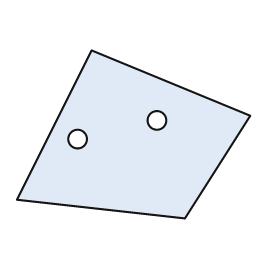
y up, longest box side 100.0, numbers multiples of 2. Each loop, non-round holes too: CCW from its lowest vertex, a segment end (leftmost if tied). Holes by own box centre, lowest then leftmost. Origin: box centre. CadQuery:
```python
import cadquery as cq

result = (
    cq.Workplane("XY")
    .moveTo(22.0, -36.0)
    .lineTo(50.0, 8.0)
    .lineTo(-18.0, 36.0)
    .lineTo(-50.0, -28.0)
    .close()
    .moveTo(-24.0, -2.0)
    .circle(4.0)
    .moveTo(10.0, 6.0)
    .circle(4.0)
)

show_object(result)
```